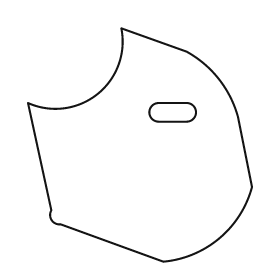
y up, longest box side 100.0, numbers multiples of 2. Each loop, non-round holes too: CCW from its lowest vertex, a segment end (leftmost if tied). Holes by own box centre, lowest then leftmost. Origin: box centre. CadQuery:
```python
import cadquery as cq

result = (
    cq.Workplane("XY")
    .moveTo(10.0, -50.0)
    .threePointArc((34.0, -40.0), (48.0, -18.0))
    .lineTo(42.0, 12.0)
    .threePointArc((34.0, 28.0), (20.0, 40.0))
    .lineTo(-8.0, 50.0)
    .threePointArc((-18.0, 22.0), (-48.0, 18.0))
    .lineTo(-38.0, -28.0)
    .threePointArc((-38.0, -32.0), (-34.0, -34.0))
    .close()
    .moveTo(8.0, 10.0)
    .lineTo(20.0, 10.0)
    .threePointArc((24.0, 14.0), (20.0, 18.0))
    .lineTo(8.0, 18.0)
    .threePointArc((4.0, 14.0), (8.0, 10.0))
    .close()
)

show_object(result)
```